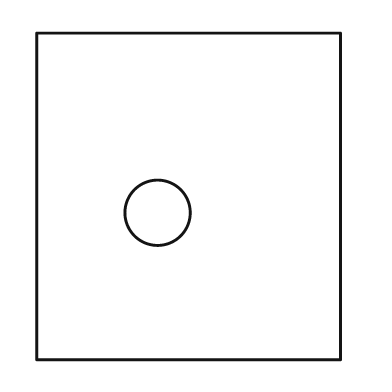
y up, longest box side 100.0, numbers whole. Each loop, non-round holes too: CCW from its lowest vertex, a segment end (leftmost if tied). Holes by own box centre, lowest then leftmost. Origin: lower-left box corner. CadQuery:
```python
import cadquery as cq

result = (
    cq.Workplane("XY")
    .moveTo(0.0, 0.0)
    .lineTo(93.0, 0.0)
    .lineTo(93.0, 100.0)
    .lineTo(0.0, 100.0)
    .close()
    .moveTo(37.0, 45.0)
    .circle(10.0)
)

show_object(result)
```